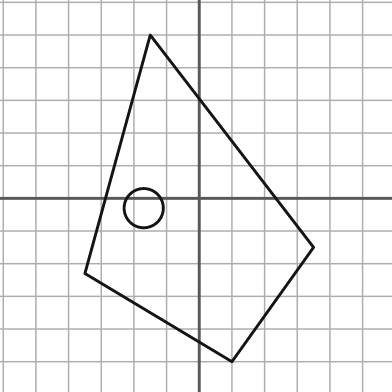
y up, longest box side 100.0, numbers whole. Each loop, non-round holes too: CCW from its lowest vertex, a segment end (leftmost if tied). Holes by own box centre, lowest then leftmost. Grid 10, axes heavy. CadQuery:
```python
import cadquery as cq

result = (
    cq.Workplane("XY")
    .moveTo(10.0, -50.0)
    .lineTo(35.0, -15.0)
    .lineTo(-15.0, 50.0)
    .lineTo(-35.0, -23.0)
    .close()
    .moveTo(-17.0, -3.0)
    .circle(6.0)
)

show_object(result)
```